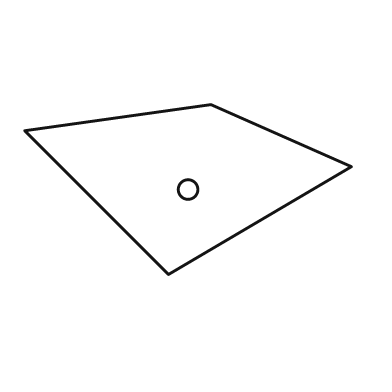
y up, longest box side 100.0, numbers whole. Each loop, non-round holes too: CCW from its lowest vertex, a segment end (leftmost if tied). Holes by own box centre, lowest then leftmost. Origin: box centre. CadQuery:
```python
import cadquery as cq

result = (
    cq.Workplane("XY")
    .moveTo(-6.0, -26.0)
    .lineTo(50.0, 7.0)
    .lineTo(7.0, 26.0)
    .lineTo(-50.0, 18.0)
    .close()
    .moveTo(0.0, 0.0)
    .circle(3.0)
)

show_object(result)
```